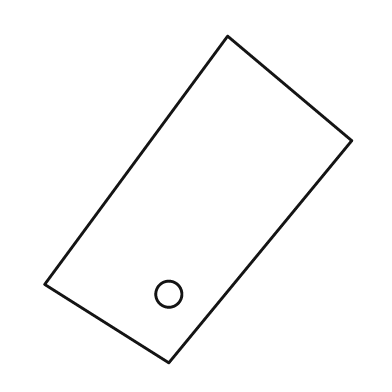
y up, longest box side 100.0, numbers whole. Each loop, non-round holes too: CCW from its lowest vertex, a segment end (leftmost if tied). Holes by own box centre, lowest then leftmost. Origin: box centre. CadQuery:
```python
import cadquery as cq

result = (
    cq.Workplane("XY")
    .moveTo(-9.0, -50.0)
    .lineTo(47.0, 18.0)
    .lineTo(9.0, 50.0)
    .lineTo(-47.0, -26.0)
    .close()
    .moveTo(-9.0, -29.0)
    .circle(4.0)
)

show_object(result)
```